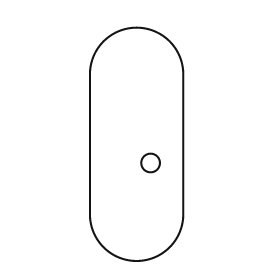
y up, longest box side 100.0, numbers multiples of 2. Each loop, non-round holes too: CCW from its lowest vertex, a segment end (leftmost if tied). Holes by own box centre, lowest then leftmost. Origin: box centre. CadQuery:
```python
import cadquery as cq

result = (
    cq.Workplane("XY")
    .moveTo(-20.0, -30.0)
    .threePointArc((0.0, -50.0), (20.0, -30.0))
    .lineTo(20.0, 30.0)
    .threePointArc((0.0, 50.0), (-20.0, 30.0))
    .close()
    .moveTo(6.0, -8.0)
    .circle(4.0)
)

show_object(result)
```